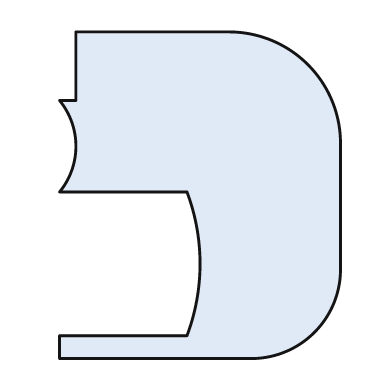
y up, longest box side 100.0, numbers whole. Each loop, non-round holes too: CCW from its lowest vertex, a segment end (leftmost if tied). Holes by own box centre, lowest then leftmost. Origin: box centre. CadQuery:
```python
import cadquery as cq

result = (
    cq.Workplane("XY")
    .moveTo(-43.0, -50.0)
    .lineTo(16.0, -50.0)
    .threePointArc((35.0, -42.0), (43.0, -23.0))
    .lineTo(43.0, 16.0)
    .threePointArc((33.0, 40.0), (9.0, 50.0))
    .lineTo(-38.0, 50.0)
    .lineTo(-38.0, 29.0)
    .lineTo(-43.0, 29.0)
    .threePointArc((-38.0, 15.0), (-43.0, 1.0))
    .lineTo(-4.0, 1.0)
    .threePointArc((0.0, -21.0), (-4.0, -43.0))
    .lineTo(-43.0, -43.0)
    .close()
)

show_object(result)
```